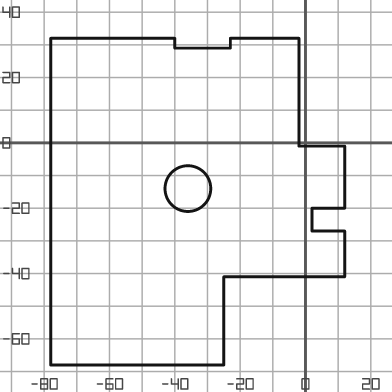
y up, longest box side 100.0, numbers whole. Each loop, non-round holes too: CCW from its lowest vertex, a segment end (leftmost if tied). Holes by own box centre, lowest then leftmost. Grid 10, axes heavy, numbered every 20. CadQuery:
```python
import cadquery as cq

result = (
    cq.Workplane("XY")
    .moveTo(-78.0, -68.0)
    .lineTo(-25.0, -68.0)
    .lineTo(-25.0, -41.0)
    .lineTo(12.0, -41.0)
    .lineTo(12.0, -27.0)
    .lineTo(2.0, -27.0)
    .lineTo(2.0, -20.0)
    .lineTo(12.0, -20.0)
    .lineTo(12.0, -1.0)
    .lineTo(-2.0, -1.0)
    .lineTo(-2.0, 32.0)
    .lineTo(-23.0, 32.0)
    .lineTo(-23.0, 29.0)
    .lineTo(-40.0, 29.0)
    .lineTo(-40.0, 32.0)
    .lineTo(-78.0, 32.0)
    .close()
    .moveTo(-36.0, -14.0)
    .circle(7.0)
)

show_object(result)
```